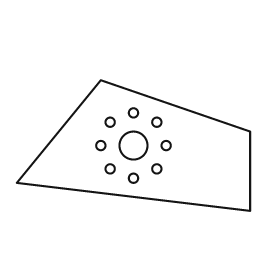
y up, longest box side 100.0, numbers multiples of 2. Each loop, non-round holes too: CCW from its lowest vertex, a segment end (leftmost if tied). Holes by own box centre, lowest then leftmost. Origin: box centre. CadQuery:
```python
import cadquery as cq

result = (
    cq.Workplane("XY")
    .moveTo(50.0, -28.0)
    .lineTo(50.0, 6.0)
    .lineTo(-14.0, 28.0)
    .lineTo(-50.0, -16.0)
    .close()
    .moveTo(0.0, -14.0)
    .circle(2.0)
    .moveTo(-10.0, -10.0)
    .circle(2.0)
    .moveTo(10.0, -10.0)
    .circle(2.0)
    .moveTo(-14.0, 0.0)
    .circle(2.0)
    .moveTo(0.0, 0.0)
    .circle(6.0)
    .moveTo(14.0, 0.0)
    .circle(2.0)
    .moveTo(-10.0, 10.0)
    .circle(2.0)
    .moveTo(10.0, 10.0)
    .circle(2.0)
    .moveTo(0.0, 14.0)
    .circle(2.0)
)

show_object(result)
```